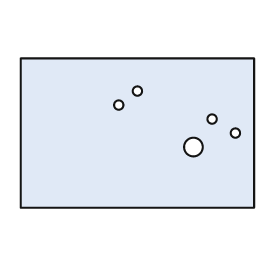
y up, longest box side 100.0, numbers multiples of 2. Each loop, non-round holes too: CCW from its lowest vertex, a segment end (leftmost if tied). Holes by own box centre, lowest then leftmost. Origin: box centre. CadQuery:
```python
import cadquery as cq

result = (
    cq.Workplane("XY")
    .moveTo(-50.0, -32.0)
    .lineTo(50.0, -32.0)
    .lineTo(50.0, 32.0)
    .lineTo(-50.0, 32.0)
    .close()
    .moveTo(24.0, -6.0)
    .circle(4.0)
    .moveTo(42.0, 0.0)
    .circle(2.0)
    .moveTo(32.0, 6.0)
    .circle(2.0)
    .moveTo(-8.0, 12.0)
    .circle(2.0)
    .moveTo(0.0, 18.0)
    .circle(2.0)
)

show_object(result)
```